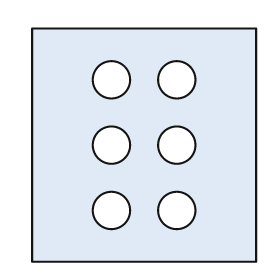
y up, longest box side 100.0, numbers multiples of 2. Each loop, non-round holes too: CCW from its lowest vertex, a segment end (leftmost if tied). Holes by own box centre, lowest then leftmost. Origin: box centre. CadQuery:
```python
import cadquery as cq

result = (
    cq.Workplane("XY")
    .moveTo(-48.0, -50.0)
    .lineTo(48.0, -50.0)
    .lineTo(48.0, 50.0)
    .lineTo(-48.0, 50.0)
    .close()
    .moveTo(-14.0, -28.0)
    .circle(8.0)
    .moveTo(14.0, -28.0)
    .circle(8.0)
    .moveTo(-14.0, 0.0)
    .circle(8.0)
    .moveTo(14.0, 0.0)
    .circle(8.0)
    .moveTo(-14.0, 28.0)
    .circle(8.0)
    .moveTo(14.0, 28.0)
    .circle(8.0)
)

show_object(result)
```